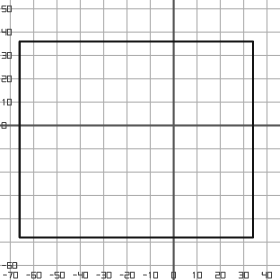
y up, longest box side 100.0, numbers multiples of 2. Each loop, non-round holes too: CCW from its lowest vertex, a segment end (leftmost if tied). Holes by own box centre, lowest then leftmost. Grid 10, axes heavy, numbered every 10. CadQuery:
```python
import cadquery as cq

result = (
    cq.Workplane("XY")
    .moveTo(-66.0, -48.0)
    .lineTo(34.0, -48.0)
    .lineTo(34.0, 36.0)
    .lineTo(-66.0, 36.0)
    .close()
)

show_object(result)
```